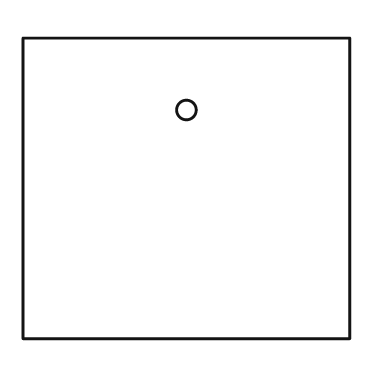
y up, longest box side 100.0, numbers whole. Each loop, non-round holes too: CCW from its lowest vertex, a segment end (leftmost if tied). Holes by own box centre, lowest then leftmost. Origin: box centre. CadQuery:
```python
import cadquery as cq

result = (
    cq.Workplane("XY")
    .moveTo(-50.0, -46.0)
    .lineTo(50.0, -46.0)
    .lineTo(50.0, 46.0)
    .lineTo(-50.0, 46.0)
    .close()
    .moveTo(0.0, 24.0)
    .circle(3.0)
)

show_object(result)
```